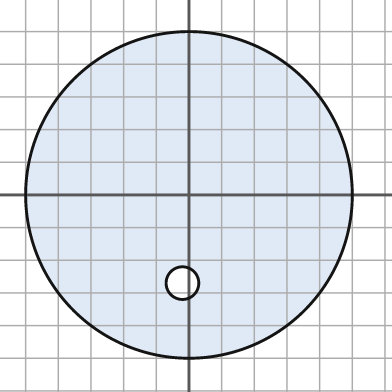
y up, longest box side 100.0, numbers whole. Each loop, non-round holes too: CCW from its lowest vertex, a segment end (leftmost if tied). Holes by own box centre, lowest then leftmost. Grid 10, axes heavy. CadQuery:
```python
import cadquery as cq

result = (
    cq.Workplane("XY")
    .moveTo(0.0, 0.0)
    .circle(50.0)
    .moveTo(-2.0, -27.0)
    .circle(5.0)
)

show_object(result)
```